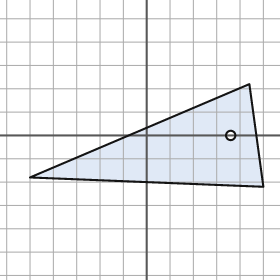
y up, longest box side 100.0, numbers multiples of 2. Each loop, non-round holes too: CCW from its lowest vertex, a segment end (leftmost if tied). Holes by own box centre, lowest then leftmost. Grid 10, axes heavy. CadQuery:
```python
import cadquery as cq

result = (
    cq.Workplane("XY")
    .moveTo(50.0, -22.0)
    .lineTo(44.0, 22.0)
    .lineTo(-50.0, -18.0)
    .close()
    .moveTo(36.0, 0.0)
    .circle(2.0)
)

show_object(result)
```